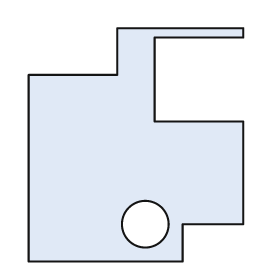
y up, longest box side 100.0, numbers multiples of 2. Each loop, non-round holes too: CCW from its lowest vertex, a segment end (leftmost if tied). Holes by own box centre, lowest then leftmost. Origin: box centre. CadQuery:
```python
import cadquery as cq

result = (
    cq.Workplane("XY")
    .moveTo(-46.0, -50.0)
    .lineTo(20.0, -50.0)
    .lineTo(20.0, -34.0)
    .lineTo(46.0, -34.0)
    .lineTo(46.0, 10.0)
    .lineTo(8.0, 10.0)
    .lineTo(8.0, 46.0)
    .lineTo(46.0, 46.0)
    .lineTo(46.0, 50.0)
    .lineTo(-8.0, 50.0)
    .lineTo(-8.0, 30.0)
    .lineTo(-46.0, 30.0)
    .close()
    .moveTo(4.0, -34.0)
    .circle(10.0)
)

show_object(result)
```